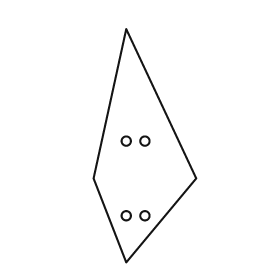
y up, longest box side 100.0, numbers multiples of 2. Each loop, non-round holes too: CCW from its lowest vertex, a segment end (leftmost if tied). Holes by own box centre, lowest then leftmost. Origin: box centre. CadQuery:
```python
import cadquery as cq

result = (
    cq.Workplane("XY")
    .moveTo(-8.0, -50.0)
    .lineTo(22.0, -14.0)
    .lineTo(-8.0, 50.0)
    .lineTo(-22.0, -14.0)
    .close()
    .moveTo(-8.0, -30.0)
    .circle(2.0)
    .moveTo(0.0, -30.0)
    .circle(2.0)
    .moveTo(-8.0, 2.0)
    .circle(2.0)
    .moveTo(0.0, 2.0)
    .circle(2.0)
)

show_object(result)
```